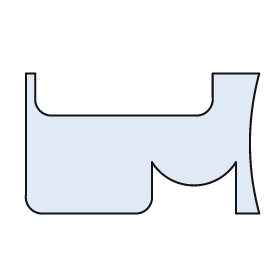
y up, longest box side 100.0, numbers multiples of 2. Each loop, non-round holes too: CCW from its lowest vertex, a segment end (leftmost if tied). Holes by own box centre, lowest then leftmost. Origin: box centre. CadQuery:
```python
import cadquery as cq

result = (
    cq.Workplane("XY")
    .moveTo(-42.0, -30.0)
    .lineTo(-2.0, -30.0)
    .threePointArc((2.0, -28.0), (4.0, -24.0))
    .lineTo(4.0, -8.0)
    .threePointArc((22.0, -18.0), (40.0, -8.0))
    .lineTo(40.0, -30.0)
    .lineTo(50.0, -30.0)
    .threePointArc((46.0, 0.0), (50.0, 30.0))
    .lineTo(30.0, 30.0)
    .lineTo(30.0, 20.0)
    .threePointArc((28.0, 14.0), (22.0, 12.0))
    .lineTo(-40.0, 12.0)
    .threePointArc((-44.0, 14.0), (-46.0, 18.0))
    .lineTo(-46.0, 30.0)
    .lineTo(-50.0, 30.0)
    .lineTo(-50.0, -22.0)
    .threePointArc((-48.0, -28.0), (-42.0, -30.0))
    .close()
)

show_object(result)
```